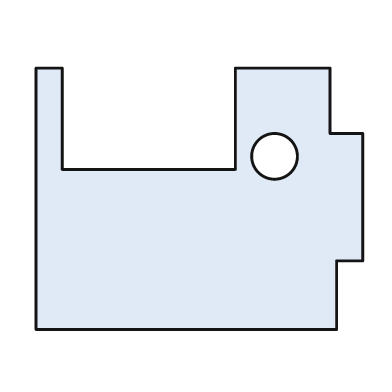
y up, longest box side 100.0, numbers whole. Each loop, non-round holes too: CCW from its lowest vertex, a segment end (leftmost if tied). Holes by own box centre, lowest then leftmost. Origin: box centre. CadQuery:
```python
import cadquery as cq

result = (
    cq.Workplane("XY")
    .moveTo(-50.0, -40.0)
    .lineTo(42.0, -40.0)
    .lineTo(42.0, -19.0)
    .lineTo(50.0, -19.0)
    .lineTo(50.0, 20.0)
    .lineTo(40.0, 20.0)
    .lineTo(40.0, 40.0)
    .lineTo(11.0, 40.0)
    .lineTo(11.0, 9.0)
    .lineTo(-42.0, 9.0)
    .lineTo(-42.0, 40.0)
    .lineTo(-50.0, 40.0)
    .close()
    .moveTo(23.0, 13.0)
    .circle(7.0)
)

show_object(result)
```